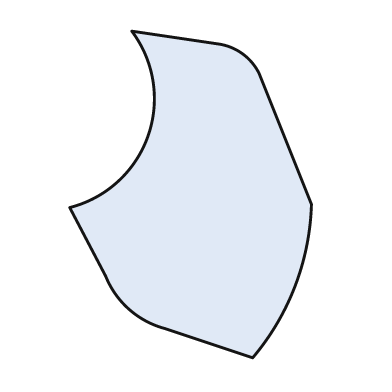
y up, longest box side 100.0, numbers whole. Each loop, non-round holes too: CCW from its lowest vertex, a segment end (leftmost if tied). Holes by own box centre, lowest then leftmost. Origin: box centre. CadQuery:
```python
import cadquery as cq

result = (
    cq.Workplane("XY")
    .moveTo(19.0, -50.0)
    .threePointArc((32.0, -28.0), (37.0, -3.0))
    .lineTo(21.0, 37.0)
    .threePointArc((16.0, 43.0), (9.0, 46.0))
    .lineTo(-18.0, 50.0)
    .threePointArc((-13.0, 18.0), (-37.0, -4.0))
    .lineTo(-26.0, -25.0)
    .threePointArc((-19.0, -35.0), (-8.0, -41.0))
    .close()
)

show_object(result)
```